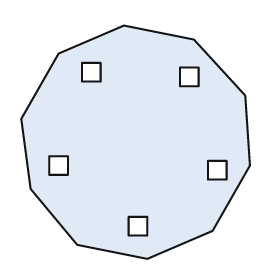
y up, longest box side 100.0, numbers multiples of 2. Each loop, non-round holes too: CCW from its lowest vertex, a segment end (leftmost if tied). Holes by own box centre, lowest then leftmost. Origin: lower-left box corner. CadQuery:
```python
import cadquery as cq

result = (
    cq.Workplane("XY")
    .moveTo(54.0, 0.0)
    .lineTo(82.0, 12.0)
    .lineTo(98.0, 40.0)
    .lineTo(96.0, 70.0)
    .lineTo(74.0, 94.0)
    .lineTo(44.0, 100.0)
    .lineTo(16.0, 88.0)
    .lineTo(0.0, 60.0)
    .lineTo(4.0, 30.0)
    .lineTo(24.0, 6.0)
    .close()
    .moveTo(46.0, 10.0)
    .lineTo(54.0, 10.0)
    .lineTo(54.0, 18.0)
    .lineTo(46.0, 18.0)
    .close()
    .moveTo(80.0, 34.0)
    .lineTo(88.0, 34.0)
    .lineTo(88.0, 42.0)
    .lineTo(80.0, 42.0)
    .close()
    .moveTo(12.0, 36.0)
    .lineTo(20.0, 36.0)
    .lineTo(20.0, 44.0)
    .lineTo(12.0, 44.0)
    .close()
    .moveTo(68.0, 74.0)
    .lineTo(76.0, 74.0)
    .lineTo(76.0, 82.0)
    .lineTo(68.0, 82.0)
    .close()
    .moveTo(26.0, 76.0)
    .lineTo(34.0, 76.0)
    .lineTo(34.0, 84.0)
    .lineTo(26.0, 84.0)
    .close()
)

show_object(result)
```